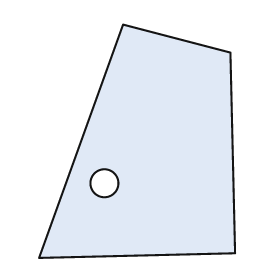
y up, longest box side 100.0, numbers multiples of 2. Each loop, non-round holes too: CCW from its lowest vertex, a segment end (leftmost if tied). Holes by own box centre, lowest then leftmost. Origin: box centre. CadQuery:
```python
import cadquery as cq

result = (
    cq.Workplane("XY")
    .moveTo(-42.0, -50.0)
    .lineTo(42.0, -48.0)
    .lineTo(40.0, 38.0)
    .lineTo(-6.0, 50.0)
    .close()
    .moveTo(-14.0, -18.0)
    .circle(6.0)
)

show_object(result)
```